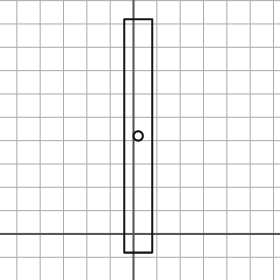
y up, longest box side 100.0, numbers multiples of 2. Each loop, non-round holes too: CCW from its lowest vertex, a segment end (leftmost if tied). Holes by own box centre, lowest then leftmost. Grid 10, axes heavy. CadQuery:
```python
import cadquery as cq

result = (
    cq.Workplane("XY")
    .moveTo(-4.0, -8.0)
    .lineTo(8.0, -8.0)
    .lineTo(8.0, 92.0)
    .lineTo(-4.0, 92.0)
    .close()
    .moveTo(2.0, 42.0)
    .circle(2.0)
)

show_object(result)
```